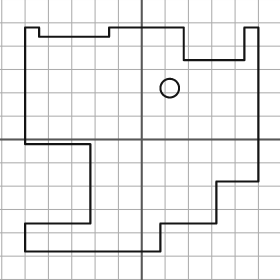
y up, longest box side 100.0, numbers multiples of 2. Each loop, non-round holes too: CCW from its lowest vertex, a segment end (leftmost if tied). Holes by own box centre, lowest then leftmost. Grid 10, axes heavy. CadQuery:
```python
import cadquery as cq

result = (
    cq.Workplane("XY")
    .moveTo(-50.0, -48.0)
    .lineTo(8.0, -48.0)
    .lineTo(8.0, -36.0)
    .lineTo(32.0, -36.0)
    .lineTo(32.0, -18.0)
    .lineTo(50.0, -18.0)
    .lineTo(50.0, 48.0)
    .lineTo(44.0, 48.0)
    .lineTo(44.0, 34.0)
    .lineTo(18.0, 34.0)
    .lineTo(18.0, 48.0)
    .lineTo(-14.0, 48.0)
    .lineTo(-14.0, 44.0)
    .lineTo(-44.0, 44.0)
    .lineTo(-44.0, 48.0)
    .lineTo(-50.0, 48.0)
    .lineTo(-50.0, -2.0)
    .lineTo(-22.0, -2.0)
    .lineTo(-22.0, -36.0)
    .lineTo(-50.0, -36.0)
    .close()
    .moveTo(12.0, 22.0)
    .circle(4.0)
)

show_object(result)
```